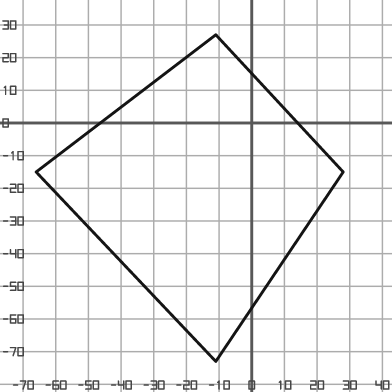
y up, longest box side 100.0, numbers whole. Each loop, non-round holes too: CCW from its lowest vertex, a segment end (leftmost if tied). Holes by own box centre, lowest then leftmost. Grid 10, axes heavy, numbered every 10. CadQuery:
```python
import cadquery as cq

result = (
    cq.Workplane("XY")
    .moveTo(-11.0, -73.0)
    .lineTo(28.0, -15.0)
    .lineTo(-11.0, 27.0)
    .lineTo(-66.0, -15.0)
    .close()
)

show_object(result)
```